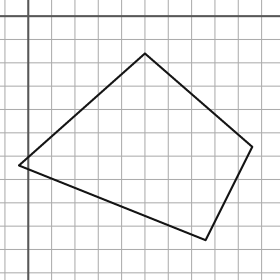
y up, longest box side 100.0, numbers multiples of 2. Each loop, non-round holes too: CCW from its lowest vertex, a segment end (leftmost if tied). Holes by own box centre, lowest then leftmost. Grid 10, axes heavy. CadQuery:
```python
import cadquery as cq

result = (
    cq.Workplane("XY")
    .moveTo(76.0, -96.0)
    .lineTo(96.0, -56.0)
    .lineTo(50.0, -16.0)
    .lineTo(-4.0, -64.0)
    .close()
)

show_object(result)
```